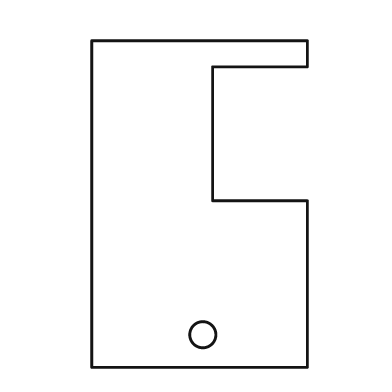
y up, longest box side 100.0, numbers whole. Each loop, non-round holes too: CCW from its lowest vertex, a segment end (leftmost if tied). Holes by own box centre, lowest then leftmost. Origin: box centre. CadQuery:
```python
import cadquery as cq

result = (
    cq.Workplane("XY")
    .moveTo(-33.0, -50.0)
    .lineTo(33.0, -50.0)
    .lineTo(33.0, 1.0)
    .lineTo(4.0, 1.0)
    .lineTo(4.0, 42.0)
    .lineTo(33.0, 42.0)
    .lineTo(33.0, 50.0)
    .lineTo(-33.0, 50.0)
    .close()
    .moveTo(1.0, -40.0)
    .circle(4.0)
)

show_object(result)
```